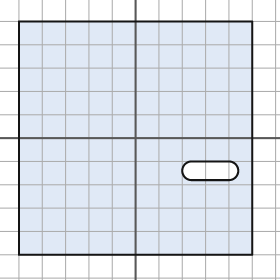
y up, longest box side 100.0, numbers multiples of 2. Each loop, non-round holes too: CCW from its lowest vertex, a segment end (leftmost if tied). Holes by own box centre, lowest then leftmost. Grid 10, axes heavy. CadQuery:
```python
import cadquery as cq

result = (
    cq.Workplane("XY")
    .moveTo(-50.0, -50.0)
    .lineTo(50.0, -50.0)
    .lineTo(50.0, 50.0)
    .lineTo(-50.0, 50.0)
    .close()
    .moveTo(24.0, -18.0)
    .lineTo(40.0, -18.0)
    .threePointArc((44.0, -14.0), (40.0, -10.0))
    .lineTo(24.0, -10.0)
    .threePointArc((20.0, -14.0), (24.0, -18.0))
    .close()
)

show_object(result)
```